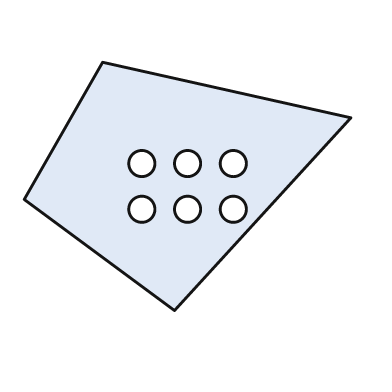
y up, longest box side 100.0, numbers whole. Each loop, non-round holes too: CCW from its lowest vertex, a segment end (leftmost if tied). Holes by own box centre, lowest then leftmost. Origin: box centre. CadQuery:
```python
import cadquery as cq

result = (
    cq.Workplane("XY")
    .moveTo(-4.0, -38.0)
    .lineTo(50.0, 21.0)
    .lineTo(-26.0, 38.0)
    .lineTo(-50.0, -4.0)
    .close()
    .moveTo(-14.0, -7.0)
    .circle(4.0)
    .moveTo(0.0, -7.0)
    .circle(4.0)
    .moveTo(14.0, -7.0)
    .circle(4.0)
    .moveTo(-14.0, 7.0)
    .circle(4.0)
    .moveTo(0.0, 7.0)
    .circle(4.0)
    .moveTo(14.0, 7.0)
    .circle(4.0)
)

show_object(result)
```